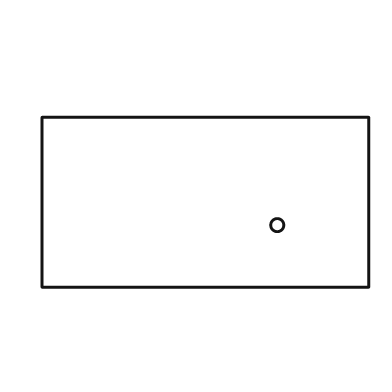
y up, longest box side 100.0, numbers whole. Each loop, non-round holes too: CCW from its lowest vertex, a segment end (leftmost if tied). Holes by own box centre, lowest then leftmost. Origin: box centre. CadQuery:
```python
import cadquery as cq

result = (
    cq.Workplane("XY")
    .moveTo(-50.0, -26.0)
    .lineTo(50.0, -26.0)
    .lineTo(50.0, 26.0)
    .lineTo(-50.0, 26.0)
    .close()
    .moveTo(22.0, -7.0)
    .circle(2.0)
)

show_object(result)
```